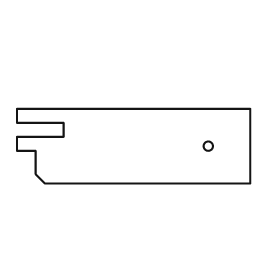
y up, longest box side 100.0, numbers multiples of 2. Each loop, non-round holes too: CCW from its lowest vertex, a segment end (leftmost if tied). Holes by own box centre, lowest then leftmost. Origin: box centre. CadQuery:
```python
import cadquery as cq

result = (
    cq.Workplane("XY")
    .moveTo(-38.0, -16.0)
    .lineTo(50.0, -16.0)
    .lineTo(50.0, 16.0)
    .lineTo(-50.0, 16.0)
    .lineTo(-50.0, 10.0)
    .lineTo(-30.0, 10.0)
    .lineTo(-30.0, 4.0)
    .lineTo(-50.0, 4.0)
    .lineTo(-50.0, -2.0)
    .lineTo(-42.0, -2.0)
    .lineTo(-42.0, -12.0)
    .close()
    .moveTo(32.0, 0.0)
    .circle(2.0)
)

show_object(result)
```